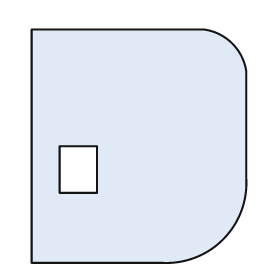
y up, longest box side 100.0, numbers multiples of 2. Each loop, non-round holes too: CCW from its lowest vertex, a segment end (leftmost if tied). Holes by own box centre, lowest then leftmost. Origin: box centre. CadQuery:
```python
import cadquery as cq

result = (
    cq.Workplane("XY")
    .moveTo(-46.0, -50.0)
    .lineTo(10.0, -50.0)
    .threePointArc((36.0, -40.0), (46.0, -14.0))
    .lineTo(46.0, 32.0)
    .threePointArc((40.0, 44.0), (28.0, 50.0))
    .lineTo(-46.0, 50.0)
    .close()
    .moveTo(-34.0, -20.0)
    .lineTo(-18.0, -20.0)
    .lineTo(-18.0, 0.0)
    .lineTo(-34.0, 0.0)
    .close()
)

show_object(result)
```